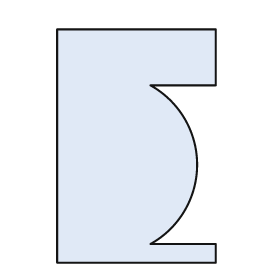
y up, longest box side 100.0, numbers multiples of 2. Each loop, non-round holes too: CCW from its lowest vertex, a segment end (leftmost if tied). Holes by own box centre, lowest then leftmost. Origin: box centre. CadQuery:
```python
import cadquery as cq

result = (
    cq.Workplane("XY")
    .moveTo(-34.0, -50.0)
    .lineTo(34.0, -50.0)
    .lineTo(34.0, -42.0)
    .lineTo(6.0, -42.0)
    .threePointArc((26.0, -8.0), (6.0, 26.0))
    .lineTo(34.0, 26.0)
    .lineTo(34.0, 50.0)
    .lineTo(-34.0, 50.0)
    .close()
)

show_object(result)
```